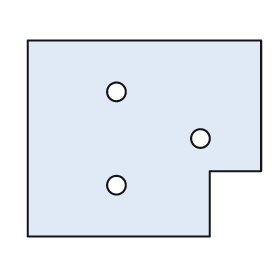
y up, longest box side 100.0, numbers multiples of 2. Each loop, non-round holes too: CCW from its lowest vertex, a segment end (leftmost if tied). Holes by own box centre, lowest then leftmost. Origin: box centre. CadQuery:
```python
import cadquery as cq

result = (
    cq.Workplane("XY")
    .moveTo(-50.0, -42.0)
    .lineTo(28.0, -42.0)
    .lineTo(28.0, -14.0)
    .lineTo(50.0, -14.0)
    .lineTo(50.0, 42.0)
    .lineTo(-50.0, 42.0)
    .close()
    .moveTo(-12.0, -20.0)
    .circle(4.0)
    .moveTo(24.0, 0.0)
    .circle(4.0)
    .moveTo(-12.0, 20.0)
    .circle(4.0)
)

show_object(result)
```